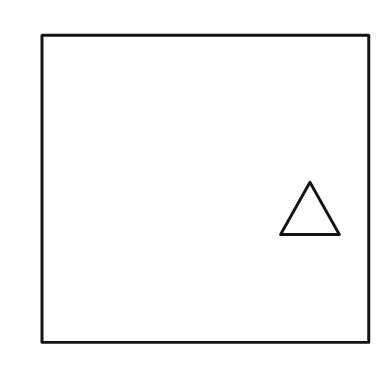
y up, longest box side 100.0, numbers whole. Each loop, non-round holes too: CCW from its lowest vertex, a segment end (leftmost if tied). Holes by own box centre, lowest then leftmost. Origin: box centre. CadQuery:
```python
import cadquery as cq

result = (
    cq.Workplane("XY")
    .moveTo(-50.0, -47.0)
    .lineTo(50.0, -47.0)
    .lineTo(50.0, 47.0)
    .lineTo(-50.0, 47.0)
    .close()
    .moveTo(23.0, -14.0)
    .lineTo(41.0, -14.0)
    .lineTo(32.0, 2.0)
    .close()
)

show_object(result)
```